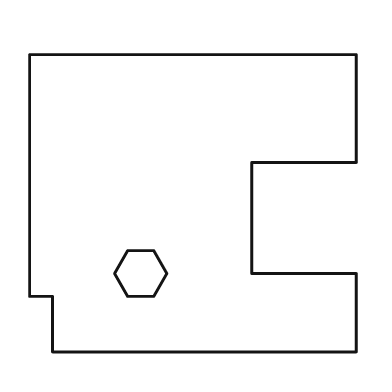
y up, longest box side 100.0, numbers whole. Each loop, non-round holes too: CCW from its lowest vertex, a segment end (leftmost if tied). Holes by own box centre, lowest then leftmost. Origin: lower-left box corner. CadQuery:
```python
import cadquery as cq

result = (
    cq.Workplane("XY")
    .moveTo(7.0, 0.0)
    .lineTo(100.0, 0.0)
    .lineTo(100.0, 24.0)
    .lineTo(68.0, 24.0)
    .lineTo(68.0, 58.0)
    .lineTo(100.0, 58.0)
    .lineTo(100.0, 91.0)
    .lineTo(0.0, 91.0)
    .lineTo(0.0, 17.0)
    .lineTo(7.0, 17.0)
    .close()
    .moveTo(30.0, 17.0)
    .lineTo(38.0, 17.0)
    .lineTo(42.0, 24.0)
    .lineTo(38.0, 31.0)
    .lineTo(30.0, 31.0)
    .lineTo(26.0, 24.0)
    .close()
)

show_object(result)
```